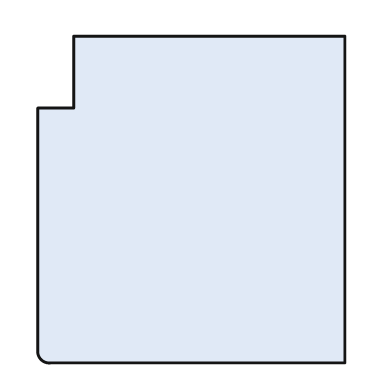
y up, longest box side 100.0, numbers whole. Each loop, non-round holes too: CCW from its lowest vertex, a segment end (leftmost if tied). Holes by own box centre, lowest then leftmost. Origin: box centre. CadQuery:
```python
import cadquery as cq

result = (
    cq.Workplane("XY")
    .moveTo(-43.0, -50.0)
    .lineTo(47.0, -50.0)
    .lineTo(47.0, 50.0)
    .lineTo(-36.0, 50.0)
    .lineTo(-36.0, 28.0)
    .lineTo(-47.0, 28.0)
    .lineTo(-47.0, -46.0)
    .threePointArc((-46.0, -49.0), (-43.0, -50.0))
    .close()
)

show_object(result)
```